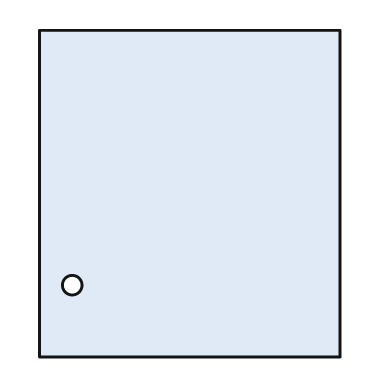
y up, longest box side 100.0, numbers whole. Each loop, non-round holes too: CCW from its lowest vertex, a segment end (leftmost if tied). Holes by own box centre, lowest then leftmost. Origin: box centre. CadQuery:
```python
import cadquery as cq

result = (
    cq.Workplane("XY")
    .moveTo(-46.0, -50.0)
    .lineTo(46.0, -50.0)
    .lineTo(46.0, 50.0)
    .lineTo(-46.0, 50.0)
    .close()
    .moveTo(-36.0, -28.0)
    .circle(3.0)
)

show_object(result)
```